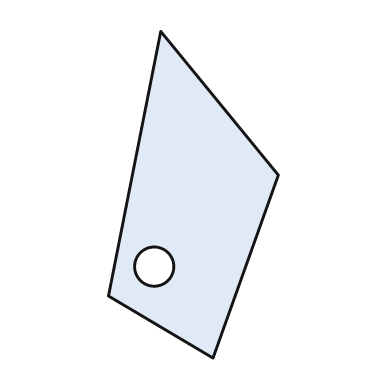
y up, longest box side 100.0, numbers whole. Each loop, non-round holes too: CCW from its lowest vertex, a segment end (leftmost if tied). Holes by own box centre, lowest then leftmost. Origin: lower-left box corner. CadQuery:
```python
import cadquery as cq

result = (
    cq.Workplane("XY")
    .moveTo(32.0, 0.0)
    .lineTo(52.0, 56.0)
    .lineTo(16.0, 100.0)
    .lineTo(0.0, 19.0)
    .close()
    .moveTo(14.0, 28.0)
    .circle(6.0)
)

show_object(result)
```